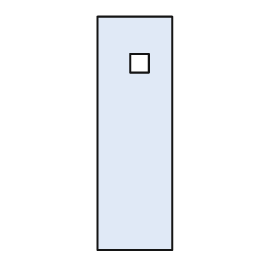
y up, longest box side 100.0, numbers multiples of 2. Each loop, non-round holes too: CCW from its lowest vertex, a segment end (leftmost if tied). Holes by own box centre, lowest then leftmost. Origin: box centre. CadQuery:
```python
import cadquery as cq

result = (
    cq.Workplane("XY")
    .moveTo(-16.0, -50.0)
    .lineTo(16.0, -50.0)
    .lineTo(16.0, 50.0)
    .lineTo(-16.0, 50.0)
    .close()
    .moveTo(-2.0, 26.0)
    .lineTo(6.0, 26.0)
    .lineTo(6.0, 34.0)
    .lineTo(-2.0, 34.0)
    .close()
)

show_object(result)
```